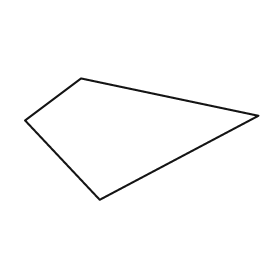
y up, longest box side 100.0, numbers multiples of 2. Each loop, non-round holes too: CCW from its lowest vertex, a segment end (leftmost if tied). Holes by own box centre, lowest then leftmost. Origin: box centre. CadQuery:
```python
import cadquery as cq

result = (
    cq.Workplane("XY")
    .moveTo(-18.0, -26.0)
    .lineTo(50.0, 10.0)
    .lineTo(-26.0, 26.0)
    .lineTo(-50.0, 8.0)
    .close()
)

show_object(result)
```